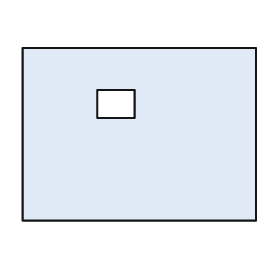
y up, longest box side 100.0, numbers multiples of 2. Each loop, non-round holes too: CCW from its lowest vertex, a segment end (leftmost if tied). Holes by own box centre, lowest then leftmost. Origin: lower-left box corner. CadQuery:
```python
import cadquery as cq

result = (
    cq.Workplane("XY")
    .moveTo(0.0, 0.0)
    .lineTo(100.0, 0.0)
    .lineTo(100.0, 74.0)
    .lineTo(0.0, 74.0)
    .close()
    .moveTo(32.0, 44.0)
    .lineTo(48.0, 44.0)
    .lineTo(48.0, 56.0)
    .lineTo(32.0, 56.0)
    .close()
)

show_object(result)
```